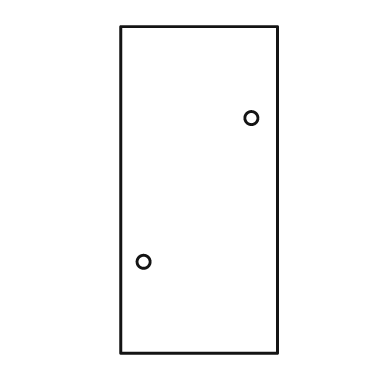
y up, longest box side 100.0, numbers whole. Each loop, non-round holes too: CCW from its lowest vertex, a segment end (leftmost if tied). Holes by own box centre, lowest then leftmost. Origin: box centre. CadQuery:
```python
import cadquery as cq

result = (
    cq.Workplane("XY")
    .moveTo(-24.0, -50.0)
    .lineTo(24.0, -50.0)
    .lineTo(24.0, 50.0)
    .lineTo(-24.0, 50.0)
    .close()
    .moveTo(-17.0, -22.0)
    .circle(2.0)
    .moveTo(16.0, 22.0)
    .circle(2.0)
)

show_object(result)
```